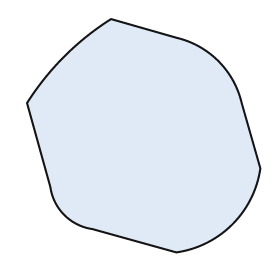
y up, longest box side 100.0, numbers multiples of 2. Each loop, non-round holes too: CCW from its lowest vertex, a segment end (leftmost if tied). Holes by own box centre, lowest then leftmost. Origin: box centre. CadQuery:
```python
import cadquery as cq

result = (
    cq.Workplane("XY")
    .moveTo(14.0, -50.0)
    .threePointArc((38.0, -38.0), (50.0, -14.0))
    .lineTo(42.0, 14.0)
    .threePointArc((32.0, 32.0), (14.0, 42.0))
    .lineTo(-14.0, 50.0)
    .threePointArc((-34.0, 34.0), (-50.0, 14.0))
    .lineTo(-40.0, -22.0)
    .threePointArc((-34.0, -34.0), (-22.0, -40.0))
    .close()
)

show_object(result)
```